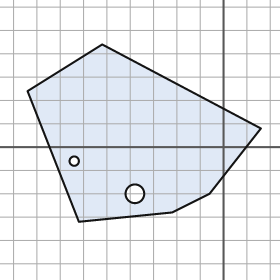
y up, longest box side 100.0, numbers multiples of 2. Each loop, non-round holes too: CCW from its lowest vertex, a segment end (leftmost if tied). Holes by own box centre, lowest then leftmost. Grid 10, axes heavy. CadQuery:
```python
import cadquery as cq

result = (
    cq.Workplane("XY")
    .moveTo(-62.0, -32.0)
    .lineTo(-22.0, -28.0)
    .lineTo(-6.0, -20.0)
    .lineTo(16.0, 8.0)
    .lineTo(-52.0, 44.0)
    .lineTo(-84.0, 24.0)
    .close()
    .moveTo(-38.0, -20.0)
    .circle(4.0)
    .moveTo(-64.0, -6.0)
    .circle(2.0)
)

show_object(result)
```